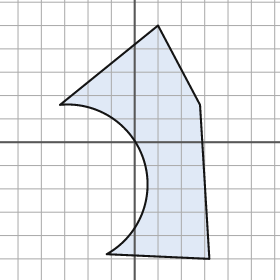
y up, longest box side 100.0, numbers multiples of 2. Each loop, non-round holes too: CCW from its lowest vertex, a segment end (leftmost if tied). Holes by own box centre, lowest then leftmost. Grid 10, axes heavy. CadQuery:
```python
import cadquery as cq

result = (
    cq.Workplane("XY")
    .moveTo(32.0, -50.0)
    .lineTo(28.0, 16.0)
    .lineTo(10.0, 50.0)
    .lineTo(-32.0, 16.0)
    .threePointArc((4.0, -8.0), (-12.0, -48.0))
    .close()
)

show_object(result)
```